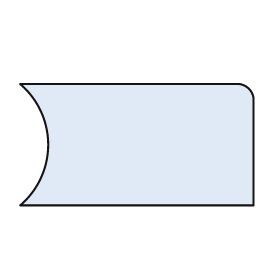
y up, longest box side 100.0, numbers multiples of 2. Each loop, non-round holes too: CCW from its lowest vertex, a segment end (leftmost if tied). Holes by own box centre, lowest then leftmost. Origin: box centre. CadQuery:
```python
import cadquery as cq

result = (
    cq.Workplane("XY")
    .moveTo(-50.0, -26.0)
    .lineTo(50.0, -26.0)
    .lineTo(50.0, 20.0)
    .threePointArc((48.0, 24.0), (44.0, 26.0))
    .lineTo(-50.0, 26.0)
    .threePointArc((-38.0, 0.0), (-50.0, -26.0))
    .close()
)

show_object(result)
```